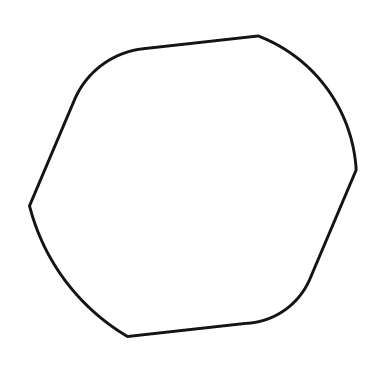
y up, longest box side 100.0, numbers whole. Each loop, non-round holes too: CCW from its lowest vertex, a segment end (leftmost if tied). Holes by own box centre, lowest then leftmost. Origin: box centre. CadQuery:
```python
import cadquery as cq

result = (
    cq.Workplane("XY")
    .moveTo(-20.0, -46.0)
    .lineTo(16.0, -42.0)
    .threePointArc((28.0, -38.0), (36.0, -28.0))
    .lineTo(50.0, 5.0)
    .threePointArc((41.0, 30.0), (20.0, 46.0))
    .lineTo(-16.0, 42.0)
    .threePointArc((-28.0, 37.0), (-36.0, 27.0))
    .lineTo(-50.0, -6.0)
    .threePointArc((-39.0, -29.0), (-20.0, -46.0))
    .close()
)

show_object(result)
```